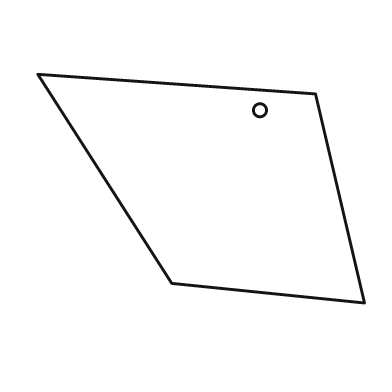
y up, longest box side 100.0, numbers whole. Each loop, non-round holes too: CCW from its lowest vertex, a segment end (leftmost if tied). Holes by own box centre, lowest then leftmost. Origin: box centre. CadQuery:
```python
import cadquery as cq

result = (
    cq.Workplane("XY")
    .moveTo(50.0, -35.0)
    .lineTo(35.0, 29.0)
    .lineTo(-50.0, 35.0)
    .lineTo(-9.0, -29.0)
    .close()
    .moveTo(18.0, 24.0)
    .circle(2.0)
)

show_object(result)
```